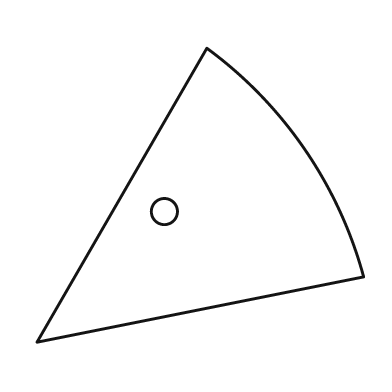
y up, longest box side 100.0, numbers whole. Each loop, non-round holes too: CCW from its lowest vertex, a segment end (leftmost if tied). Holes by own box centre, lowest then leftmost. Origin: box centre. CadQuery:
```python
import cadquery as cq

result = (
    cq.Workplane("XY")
    .moveTo(-50.0, -45.0)
    .lineTo(50.0, -25.0)
    .threePointArc((32.0, 14.0), (2.0, 45.0))
    .close()
    .moveTo(-11.0, -5.0)
    .circle(4.0)
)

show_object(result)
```